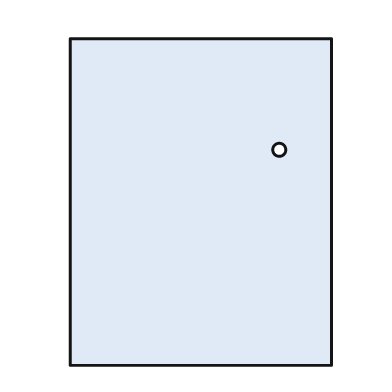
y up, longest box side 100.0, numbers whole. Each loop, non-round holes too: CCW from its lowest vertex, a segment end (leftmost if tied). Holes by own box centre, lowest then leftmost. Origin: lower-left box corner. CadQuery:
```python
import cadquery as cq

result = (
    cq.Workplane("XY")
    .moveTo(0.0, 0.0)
    .lineTo(80.0, 0.0)
    .lineTo(80.0, 100.0)
    .lineTo(0.0, 100.0)
    .close()
    .moveTo(64.0, 66.0)
    .circle(2.0)
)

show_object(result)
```